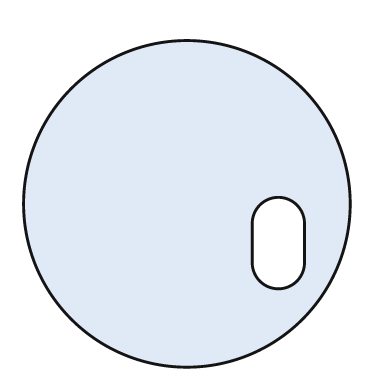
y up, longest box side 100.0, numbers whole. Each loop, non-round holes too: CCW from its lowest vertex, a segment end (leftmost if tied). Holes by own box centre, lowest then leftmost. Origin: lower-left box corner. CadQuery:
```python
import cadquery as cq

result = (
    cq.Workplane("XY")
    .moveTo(50.0, 50.0)
    .circle(50.0)
    .moveTo(70.0, 32.0)
    .threePointArc((78.0, 24.0), (86.0, 32.0))
    .lineTo(86.0, 44.0)
    .threePointArc((78.0, 52.0), (70.0, 44.0))
    .close()
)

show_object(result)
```